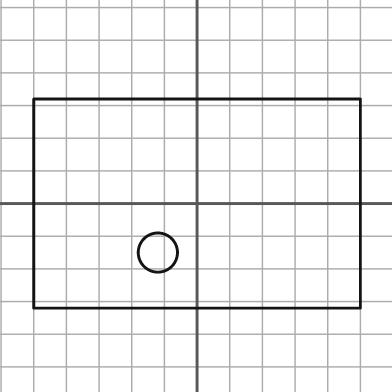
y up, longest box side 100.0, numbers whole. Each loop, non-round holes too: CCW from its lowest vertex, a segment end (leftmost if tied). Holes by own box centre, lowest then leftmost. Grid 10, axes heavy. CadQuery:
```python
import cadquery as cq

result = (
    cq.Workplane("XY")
    .moveTo(-50.0, -32.0)
    .lineTo(50.0, -32.0)
    .lineTo(50.0, 32.0)
    .lineTo(-50.0, 32.0)
    .close()
    .moveTo(-12.0, -15.0)
    .circle(6.0)
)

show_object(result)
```